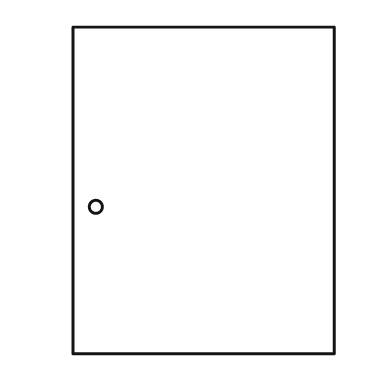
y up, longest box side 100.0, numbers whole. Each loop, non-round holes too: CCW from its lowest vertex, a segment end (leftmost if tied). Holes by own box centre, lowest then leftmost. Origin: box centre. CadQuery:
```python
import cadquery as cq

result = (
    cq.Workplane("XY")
    .moveTo(-40.0, -50.0)
    .lineTo(40.0, -50.0)
    .lineTo(40.0, 50.0)
    .lineTo(-40.0, 50.0)
    .close()
    .moveTo(-33.0, -5.0)
    .circle(2.0)
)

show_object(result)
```